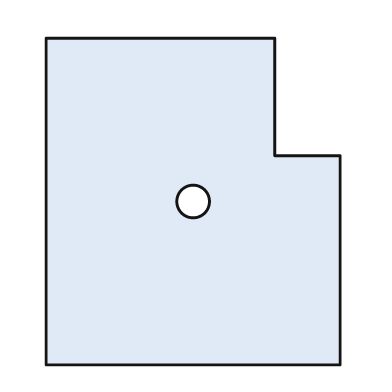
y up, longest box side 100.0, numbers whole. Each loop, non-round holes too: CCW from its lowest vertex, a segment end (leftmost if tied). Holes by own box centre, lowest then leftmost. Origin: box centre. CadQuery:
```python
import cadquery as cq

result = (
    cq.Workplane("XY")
    .moveTo(-45.0, -50.0)
    .lineTo(45.0, -50.0)
    .lineTo(45.0, 14.0)
    .lineTo(25.0, 14.0)
    .lineTo(25.0, 50.0)
    .lineTo(-45.0, 50.0)
    .close()
    .moveTo(0.0, 0.0)
    .circle(5.0)
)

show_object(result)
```